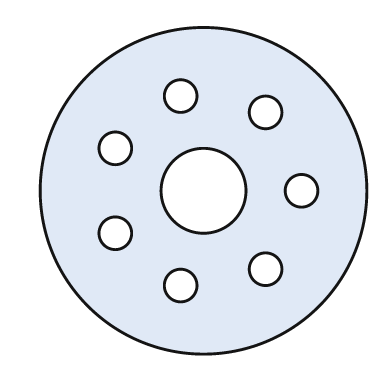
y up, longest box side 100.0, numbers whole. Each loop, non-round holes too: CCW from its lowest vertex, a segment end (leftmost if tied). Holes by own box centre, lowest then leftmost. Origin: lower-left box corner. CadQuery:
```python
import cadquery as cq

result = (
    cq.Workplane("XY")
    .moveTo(50.0, 50.0)
    .circle(50.0)
    .moveTo(43.0, 21.0)
    .circle(5.0)
    .moveTo(69.0, 26.0)
    .circle(5.0)
    .moveTo(23.0, 37.0)
    .circle(5.0)
    .moveTo(50.0, 50.0)
    .circle(13.0)
    .moveTo(80.0, 50.0)
    .circle(5.0)
    .moveTo(23.0, 63.0)
    .circle(5.0)
    .moveTo(69.0, 74.0)
    .circle(5.0)
    .moveTo(43.0, 79.0)
    .circle(5.0)
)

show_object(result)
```